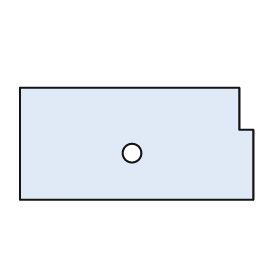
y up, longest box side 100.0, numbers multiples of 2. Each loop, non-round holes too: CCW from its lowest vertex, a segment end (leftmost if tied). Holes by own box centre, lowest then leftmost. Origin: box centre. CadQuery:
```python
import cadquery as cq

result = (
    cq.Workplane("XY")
    .moveTo(-50.0, -24.0)
    .lineTo(50.0, -24.0)
    .lineTo(50.0, 6.0)
    .lineTo(44.0, 6.0)
    .lineTo(44.0, 24.0)
    .lineTo(-50.0, 24.0)
    .close()
    .moveTo(-2.0, -4.0)
    .circle(4.0)
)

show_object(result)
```